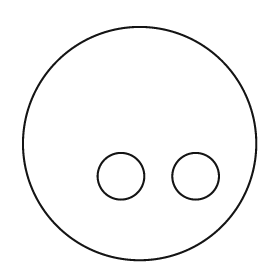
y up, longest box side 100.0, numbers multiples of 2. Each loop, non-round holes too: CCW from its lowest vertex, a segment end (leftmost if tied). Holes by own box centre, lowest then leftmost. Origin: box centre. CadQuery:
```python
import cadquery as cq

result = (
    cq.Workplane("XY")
    .moveTo(0.0, 0.0)
    .circle(50.0)
    .moveTo(-8.0, -14.0)
    .circle(10.0)
    .moveTo(24.0, -14.0)
    .circle(10.0)
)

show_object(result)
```